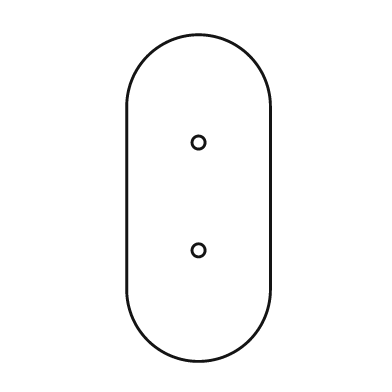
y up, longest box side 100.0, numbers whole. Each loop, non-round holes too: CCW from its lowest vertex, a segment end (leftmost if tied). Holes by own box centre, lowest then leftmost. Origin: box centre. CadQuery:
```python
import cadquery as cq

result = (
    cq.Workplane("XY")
    .moveTo(-22.0, -28.0)
    .threePointArc((0.0, -50.0), (22.0, -28.0))
    .lineTo(22.0, 28.0)
    .threePointArc((0.0, 50.0), (-22.0, 28.0))
    .close()
    .moveTo(0.0, -16.0)
    .circle(2.0)
    .moveTo(0.0, 17.0)
    .circle(2.0)
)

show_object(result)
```